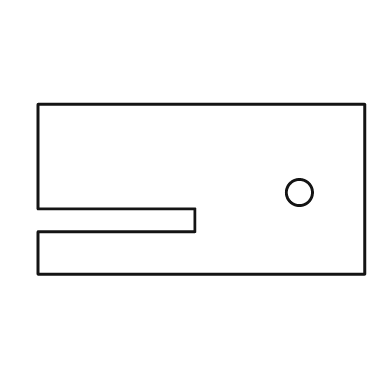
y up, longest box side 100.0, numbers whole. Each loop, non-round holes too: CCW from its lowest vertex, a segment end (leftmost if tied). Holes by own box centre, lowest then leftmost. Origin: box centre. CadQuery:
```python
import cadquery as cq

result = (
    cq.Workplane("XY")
    .moveTo(-50.0, -26.0)
    .lineTo(50.0, -26.0)
    .lineTo(50.0, 26.0)
    .lineTo(-50.0, 26.0)
    .lineTo(-50.0, -6.0)
    .lineTo(-2.0, -6.0)
    .lineTo(-2.0, -13.0)
    .lineTo(-50.0, -13.0)
    .close()
    .moveTo(30.0, -1.0)
    .circle(4.0)
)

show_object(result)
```